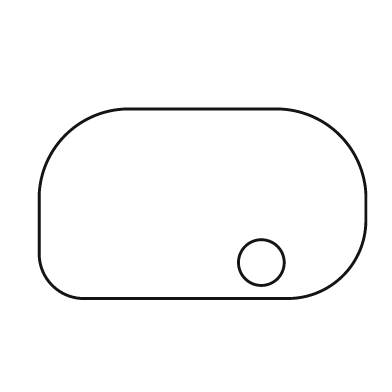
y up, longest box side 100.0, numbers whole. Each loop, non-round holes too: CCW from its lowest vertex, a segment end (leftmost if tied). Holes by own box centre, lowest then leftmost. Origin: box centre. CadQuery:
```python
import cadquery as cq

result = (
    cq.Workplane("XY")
    .moveTo(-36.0, -29.0)
    .lineTo(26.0, -29.0)
    .threePointArc((43.0, -22.0), (50.0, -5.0))
    .lineTo(50.0, 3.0)
    .threePointArc((42.0, 21.0), (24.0, 29.0))
    .lineTo(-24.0, 29.0)
    .threePointArc((-42.0, 21.0), (-50.0, 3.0))
    .lineTo(-50.0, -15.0)
    .threePointArc((-46.0, -25.0), (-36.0, -29.0))
    .close()
    .moveTo(18.0, -18.0)
    .circle(7.0)
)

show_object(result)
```